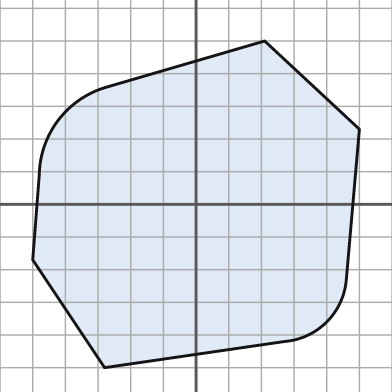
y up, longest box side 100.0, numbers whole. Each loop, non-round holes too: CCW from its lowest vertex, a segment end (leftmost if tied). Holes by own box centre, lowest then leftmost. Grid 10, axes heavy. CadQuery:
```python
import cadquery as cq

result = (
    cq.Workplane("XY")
    .moveTo(-28.0, -50.0)
    .lineTo(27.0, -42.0)
    .threePointArc((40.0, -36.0), (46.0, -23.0))
    .lineTo(50.0, 23.0)
    .lineTo(21.0, 50.0)
    .lineTo(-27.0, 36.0)
    .threePointArc((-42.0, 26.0), (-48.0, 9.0))
    .lineTo(-50.0, -17.0)
    .close()
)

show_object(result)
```